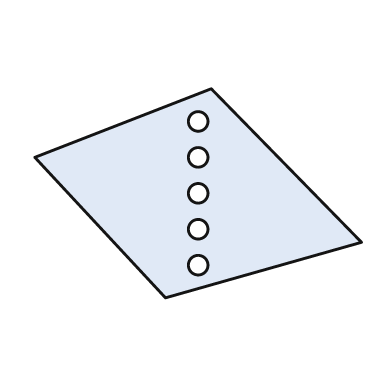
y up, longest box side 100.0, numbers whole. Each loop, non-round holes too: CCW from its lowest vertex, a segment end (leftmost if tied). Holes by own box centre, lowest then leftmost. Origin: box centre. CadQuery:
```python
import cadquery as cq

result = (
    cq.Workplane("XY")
    .moveTo(-10.0, -32.0)
    .lineTo(50.0, -15.0)
    .lineTo(4.0, 32.0)
    .lineTo(-50.0, 11.0)
    .close()
    .moveTo(0.0, -22.0)
    .circle(3.0)
    .moveTo(0.0, -11.0)
    .circle(3.0)
    .moveTo(0.0, 0.0)
    .circle(3.0)
    .moveTo(0.0, 11.0)
    .circle(3.0)
    .moveTo(0.0, 22.0)
    .circle(3.0)
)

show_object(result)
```